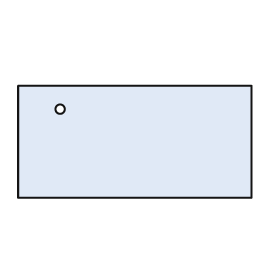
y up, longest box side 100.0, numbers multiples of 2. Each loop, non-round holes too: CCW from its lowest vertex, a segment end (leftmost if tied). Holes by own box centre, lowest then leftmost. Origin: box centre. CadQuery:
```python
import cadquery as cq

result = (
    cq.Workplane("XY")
    .moveTo(-50.0, -24.0)
    .lineTo(50.0, -24.0)
    .lineTo(50.0, 24.0)
    .lineTo(-50.0, 24.0)
    .close()
    .moveTo(-32.0, 14.0)
    .circle(2.0)
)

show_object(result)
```